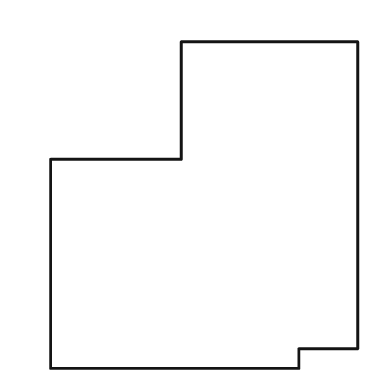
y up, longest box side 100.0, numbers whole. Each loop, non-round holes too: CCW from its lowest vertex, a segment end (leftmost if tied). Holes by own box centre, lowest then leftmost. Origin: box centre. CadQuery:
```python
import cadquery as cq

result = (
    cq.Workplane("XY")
    .moveTo(-47.0, -50.0)
    .lineTo(29.0, -50.0)
    .lineTo(29.0, -44.0)
    .lineTo(47.0, -44.0)
    .lineTo(47.0, 50.0)
    .lineTo(-7.0, 50.0)
    .lineTo(-7.0, 14.0)
    .lineTo(-47.0, 14.0)
    .close()
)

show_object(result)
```